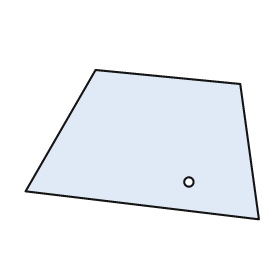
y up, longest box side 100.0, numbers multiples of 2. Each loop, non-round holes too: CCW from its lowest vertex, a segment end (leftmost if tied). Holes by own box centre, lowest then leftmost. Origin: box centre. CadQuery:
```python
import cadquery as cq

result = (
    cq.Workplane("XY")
    .moveTo(50.0, -32.0)
    .lineTo(42.0, 26.0)
    .lineTo(-20.0, 32.0)
    .lineTo(-50.0, -20.0)
    .close()
    .moveTo(20.0, -16.0)
    .circle(2.0)
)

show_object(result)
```